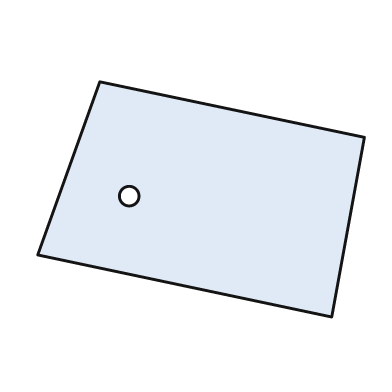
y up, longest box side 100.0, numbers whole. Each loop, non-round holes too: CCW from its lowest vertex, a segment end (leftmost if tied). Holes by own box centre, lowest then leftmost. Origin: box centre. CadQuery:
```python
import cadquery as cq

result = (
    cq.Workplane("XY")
    .moveTo(40.0, -36.0)
    .lineTo(50.0, 19.0)
    .lineTo(-31.0, 36.0)
    .lineTo(-50.0, -17.0)
    .close()
    .moveTo(-22.0, 1.0)
    .circle(3.0)
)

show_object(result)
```